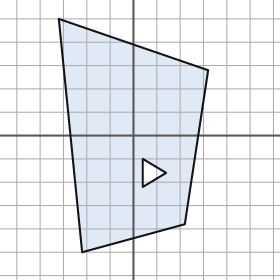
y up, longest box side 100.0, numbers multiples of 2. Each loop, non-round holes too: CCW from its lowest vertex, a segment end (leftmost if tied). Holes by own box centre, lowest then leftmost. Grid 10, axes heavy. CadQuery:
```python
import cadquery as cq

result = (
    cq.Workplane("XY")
    .moveTo(-22.0, -50.0)
    .lineTo(22.0, -38.0)
    .lineTo(32.0, 28.0)
    .lineTo(-32.0, 50.0)
    .close()
    .moveTo(4.0, -22.0)
    .lineTo(14.0, -16.0)
    .lineTo(4.0, -10.0)
    .close()
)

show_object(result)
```